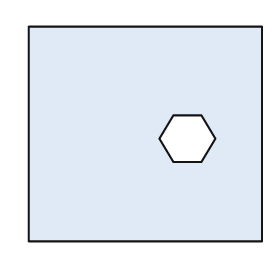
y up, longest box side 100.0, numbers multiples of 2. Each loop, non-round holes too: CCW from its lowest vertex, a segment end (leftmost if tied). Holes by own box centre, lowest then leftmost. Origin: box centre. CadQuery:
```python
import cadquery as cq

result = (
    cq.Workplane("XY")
    .moveTo(-50.0, -46.0)
    .lineTo(50.0, -46.0)
    .lineTo(50.0, 46.0)
    .lineTo(-50.0, 46.0)
    .close()
    .moveTo(12.0, -12.0)
    .lineTo(24.0, -12.0)
    .lineTo(30.0, -2.0)
    .lineTo(24.0, 8.0)
    .lineTo(12.0, 8.0)
    .lineTo(6.0, -2.0)
    .close()
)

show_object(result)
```